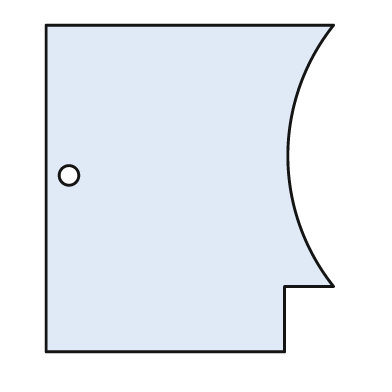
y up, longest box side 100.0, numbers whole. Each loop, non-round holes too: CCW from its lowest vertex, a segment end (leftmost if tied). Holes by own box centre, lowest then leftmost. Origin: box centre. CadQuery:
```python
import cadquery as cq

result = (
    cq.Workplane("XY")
    .moveTo(-44.0, -50.0)
    .lineTo(29.0, -50.0)
    .lineTo(29.0, -30.0)
    .lineTo(44.0, -30.0)
    .threePointArc((30.0, 10.0), (44.0, 50.0))
    .lineTo(-44.0, 50.0)
    .close()
    .moveTo(-37.0, 4.0)
    .circle(3.0)
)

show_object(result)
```